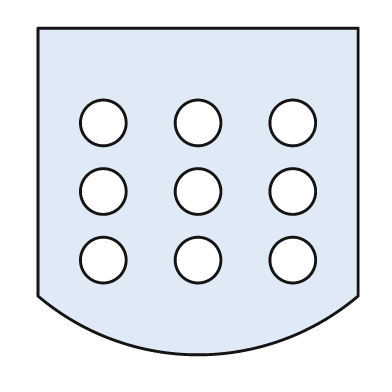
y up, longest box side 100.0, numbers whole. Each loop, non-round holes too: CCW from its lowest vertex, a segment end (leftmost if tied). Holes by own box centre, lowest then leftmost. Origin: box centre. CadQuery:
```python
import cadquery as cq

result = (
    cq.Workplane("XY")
    .moveTo(-49.0, -32.0)
    .threePointArc((0.0, -50.0), (49.0, -32.0))
    .lineTo(49.0, 50.0)
    .lineTo(-49.0, 50.0)
    .close()
    .moveTo(-29.0, -21.0)
    .circle(7.0)
    .moveTo(0.0, -21.0)
    .circle(7.0)
    .moveTo(29.0, -21.0)
    .circle(7.0)
    .moveTo(-29.0, 0.0)
    .circle(7.0)
    .moveTo(0.0, 0.0)
    .circle(7.0)
    .moveTo(29.0, 0.0)
    .circle(7.0)
    .moveTo(-29.0, 21.0)
    .circle(7.0)
    .moveTo(0.0, 21.0)
    .circle(7.0)
    .moveTo(29.0, 21.0)
    .circle(7.0)
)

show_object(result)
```